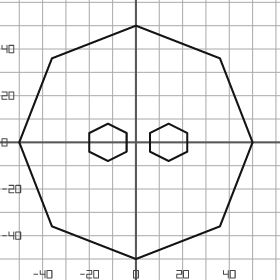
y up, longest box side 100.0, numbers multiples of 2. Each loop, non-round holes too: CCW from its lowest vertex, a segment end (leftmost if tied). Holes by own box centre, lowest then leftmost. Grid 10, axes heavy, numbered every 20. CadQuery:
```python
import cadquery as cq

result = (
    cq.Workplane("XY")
    .moveTo(0.0, -50.0)
    .lineTo(36.0, -36.0)
    .lineTo(50.0, 0.0)
    .lineTo(36.0, 36.0)
    .lineTo(0.0, 50.0)
    .lineTo(-36.0, 36.0)
    .lineTo(-50.0, 0.0)
    .lineTo(-36.0, -36.0)
    .close()
    .moveTo(-12.0, -8.0)
    .lineTo(-4.0, -4.0)
    .lineTo(-4.0, 4.0)
    .lineTo(-12.0, 8.0)
    .lineTo(-20.0, 4.0)
    .lineTo(-20.0, -4.0)
    .close()
    .moveTo(14.0, -8.0)
    .lineTo(22.0, -4.0)
    .lineTo(22.0, 4.0)
    .lineTo(14.0, 8.0)
    .lineTo(6.0, 4.0)
    .lineTo(6.0, -4.0)
    .close()
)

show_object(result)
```